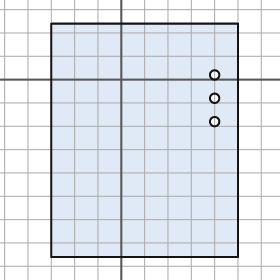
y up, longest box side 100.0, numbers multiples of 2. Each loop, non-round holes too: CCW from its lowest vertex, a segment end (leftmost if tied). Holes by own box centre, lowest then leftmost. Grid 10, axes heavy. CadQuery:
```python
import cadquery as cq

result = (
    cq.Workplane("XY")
    .moveTo(-30.0, -76.0)
    .lineTo(50.0, -76.0)
    .lineTo(50.0, 24.0)
    .lineTo(-30.0, 24.0)
    .close()
    .moveTo(40.0, -18.0)
    .circle(2.0)
    .moveTo(40.0, -8.0)
    .circle(2.0)
    .moveTo(40.0, 2.0)
    .circle(2.0)
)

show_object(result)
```